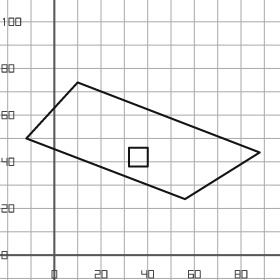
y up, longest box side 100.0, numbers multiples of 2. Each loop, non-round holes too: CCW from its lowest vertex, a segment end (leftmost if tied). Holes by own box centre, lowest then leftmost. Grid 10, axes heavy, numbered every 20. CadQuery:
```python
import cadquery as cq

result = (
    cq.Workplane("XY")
    .moveTo(56.0, 24.0)
    .lineTo(88.0, 44.0)
    .lineTo(10.0, 74.0)
    .lineTo(-12.0, 50.0)
    .close()
    .moveTo(32.0, 38.0)
    .lineTo(40.0, 38.0)
    .lineTo(40.0, 46.0)
    .lineTo(32.0, 46.0)
    .close()
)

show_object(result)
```